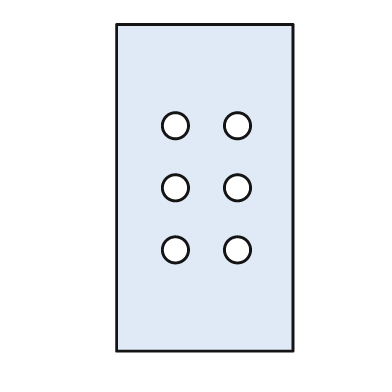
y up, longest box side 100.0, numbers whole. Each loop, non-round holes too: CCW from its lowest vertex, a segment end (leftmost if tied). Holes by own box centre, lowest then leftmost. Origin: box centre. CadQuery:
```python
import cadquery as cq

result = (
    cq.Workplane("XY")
    .moveTo(-27.0, -50.0)
    .lineTo(27.0, -50.0)
    .lineTo(27.0, 50.0)
    .lineTo(-27.0, 50.0)
    .close()
    .moveTo(-9.0, -19.0)
    .circle(4.0)
    .moveTo(10.0, -19.0)
    .circle(4.0)
    .moveTo(-9.0, 0.0)
    .circle(4.0)
    .moveTo(10.0, 0.0)
    .circle(4.0)
    .moveTo(-9.0, 19.0)
    .circle(4.0)
    .moveTo(10.0, 19.0)
    .circle(4.0)
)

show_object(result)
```